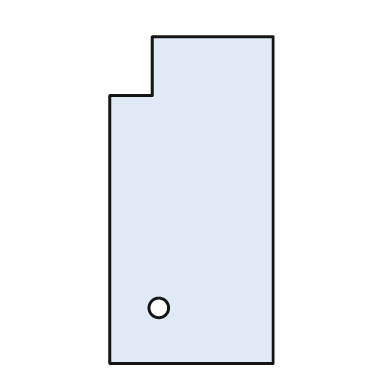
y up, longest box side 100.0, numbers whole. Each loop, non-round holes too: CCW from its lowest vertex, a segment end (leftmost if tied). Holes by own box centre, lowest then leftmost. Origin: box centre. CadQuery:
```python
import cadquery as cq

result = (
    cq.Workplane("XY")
    .moveTo(-25.0, -50.0)
    .lineTo(25.0, -50.0)
    .lineTo(25.0, 50.0)
    .lineTo(-12.0, 50.0)
    .lineTo(-12.0, 32.0)
    .lineTo(-25.0, 32.0)
    .close()
    .moveTo(-10.0, -33.0)
    .circle(3.0)
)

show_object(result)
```